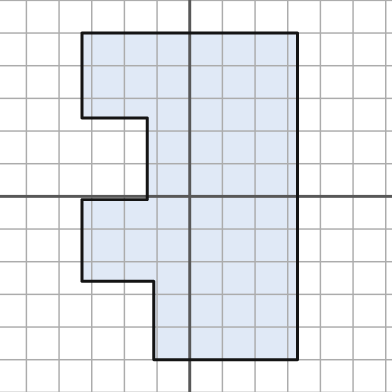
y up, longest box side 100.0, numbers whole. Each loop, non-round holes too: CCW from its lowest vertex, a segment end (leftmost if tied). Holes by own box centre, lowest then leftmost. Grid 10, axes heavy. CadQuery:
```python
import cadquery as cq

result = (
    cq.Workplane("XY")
    .moveTo(-11.0, -50.0)
    .lineTo(33.0, -50.0)
    .lineTo(33.0, 50.0)
    .lineTo(-33.0, 50.0)
    .lineTo(-33.0, 24.0)
    .lineTo(-13.0, 24.0)
    .lineTo(-13.0, -1.0)
    .lineTo(-33.0, -1.0)
    .lineTo(-33.0, -26.0)
    .lineTo(-11.0, -26.0)
    .close()
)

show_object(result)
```